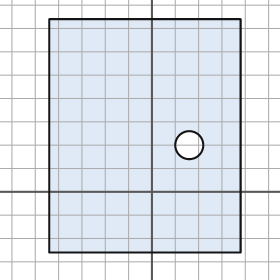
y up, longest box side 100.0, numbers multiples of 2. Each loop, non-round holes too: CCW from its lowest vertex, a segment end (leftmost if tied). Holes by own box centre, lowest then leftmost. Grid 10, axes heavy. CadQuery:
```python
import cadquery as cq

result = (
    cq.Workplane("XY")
    .moveTo(-44.0, -26.0)
    .lineTo(38.0, -26.0)
    .lineTo(38.0, 74.0)
    .lineTo(-44.0, 74.0)
    .close()
    .moveTo(16.0, 20.0)
    .circle(6.0)
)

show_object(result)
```